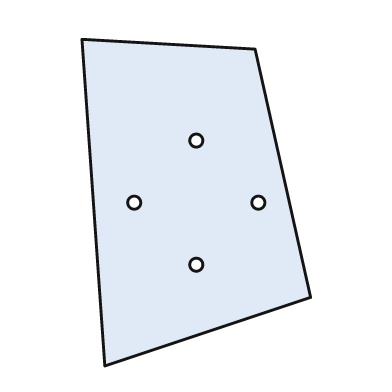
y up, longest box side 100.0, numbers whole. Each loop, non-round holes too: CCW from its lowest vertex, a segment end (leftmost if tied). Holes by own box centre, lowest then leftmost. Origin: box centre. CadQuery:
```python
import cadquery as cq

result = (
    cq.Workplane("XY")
    .moveTo(-28.0, -50.0)
    .lineTo(35.0, -29.0)
    .lineTo(18.0, 47.0)
    .lineTo(-35.0, 50.0)
    .close()
    .moveTo(0.0, -19.0)
    .circle(2.0)
    .moveTo(-19.0, 0.0)
    .circle(2.0)
    .moveTo(19.0, 0.0)
    .circle(2.0)
    .moveTo(0.0, 19.0)
    .circle(2.0)
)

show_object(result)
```